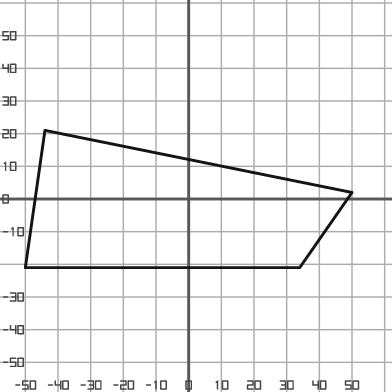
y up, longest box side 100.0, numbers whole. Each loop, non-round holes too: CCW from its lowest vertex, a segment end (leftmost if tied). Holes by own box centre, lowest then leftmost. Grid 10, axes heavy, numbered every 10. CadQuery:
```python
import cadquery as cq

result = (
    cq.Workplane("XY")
    .moveTo(-50.0, -21.0)
    .lineTo(34.0, -21.0)
    .lineTo(50.0, 2.0)
    .lineTo(-44.0, 21.0)
    .close()
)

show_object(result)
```